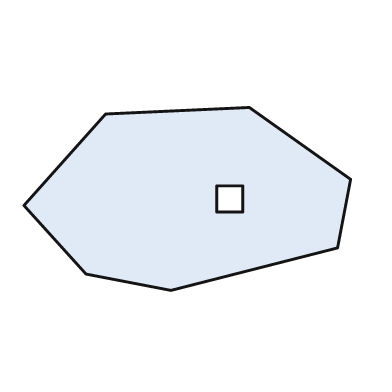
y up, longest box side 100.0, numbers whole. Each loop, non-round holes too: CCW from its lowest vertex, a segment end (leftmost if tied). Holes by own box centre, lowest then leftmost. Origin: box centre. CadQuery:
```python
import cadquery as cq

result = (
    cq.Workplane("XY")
    .moveTo(-5.0, -28.0)
    .lineTo(46.0, -15.0)
    .lineTo(50.0, 6.0)
    .lineTo(19.0, 28.0)
    .lineTo(-25.0, 26.0)
    .lineTo(-50.0, -2.0)
    .lineTo(-31.0, -23.0)
    .close()
    .moveTo(9.0, -4.0)
    .lineTo(17.0, -4.0)
    .lineTo(17.0, 4.0)
    .lineTo(9.0, 4.0)
    .close()
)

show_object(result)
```